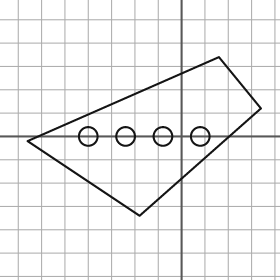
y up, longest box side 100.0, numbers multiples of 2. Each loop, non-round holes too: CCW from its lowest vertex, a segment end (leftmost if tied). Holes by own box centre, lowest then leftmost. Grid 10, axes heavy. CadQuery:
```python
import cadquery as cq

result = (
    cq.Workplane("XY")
    .moveTo(-18.0, -34.0)
    .lineTo(34.0, 12.0)
    .lineTo(16.0, 34.0)
    .lineTo(-66.0, -2.0)
    .close()
    .moveTo(-40.0, 0.0)
    .circle(4.0)
    .moveTo(-24.0, 0.0)
    .circle(4.0)
    .moveTo(-8.0, 0.0)
    .circle(4.0)
    .moveTo(8.0, 0.0)
    .circle(4.0)
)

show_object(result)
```